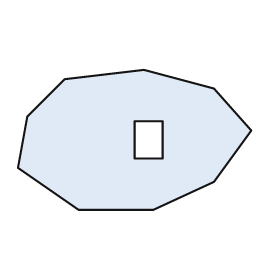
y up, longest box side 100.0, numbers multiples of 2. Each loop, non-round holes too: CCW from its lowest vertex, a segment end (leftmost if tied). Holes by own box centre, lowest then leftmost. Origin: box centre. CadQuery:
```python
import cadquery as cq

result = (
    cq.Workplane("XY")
    .moveTo(-24.0, -30.0)
    .lineTo(8.0, -30.0)
    .lineTo(34.0, -18.0)
    .lineTo(50.0, 4.0)
    .lineTo(34.0, 22.0)
    .lineTo(4.0, 30.0)
    .lineTo(-30.0, 26.0)
    .lineTo(-46.0, 10.0)
    .lineTo(-50.0, -12.0)
    .close()
    .moveTo(0.0, -8.0)
    .lineTo(12.0, -8.0)
    .lineTo(12.0, 8.0)
    .lineTo(0.0, 8.0)
    .close()
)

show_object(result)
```